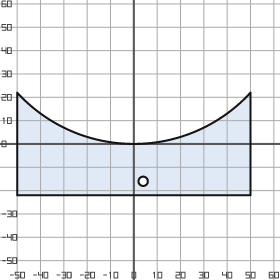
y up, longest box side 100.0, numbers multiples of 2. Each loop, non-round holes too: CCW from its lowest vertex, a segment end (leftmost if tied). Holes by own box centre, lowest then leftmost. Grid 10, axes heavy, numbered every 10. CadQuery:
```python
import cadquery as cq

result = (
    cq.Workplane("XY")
    .moveTo(-50.0, -22.0)
    .lineTo(50.0, -22.0)
    .lineTo(50.0, 22.0)
    .threePointArc((0.0, 0.0), (-50.0, 22.0))
    .close()
    .moveTo(4.0, -16.0)
    .circle(2.0)
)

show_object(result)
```